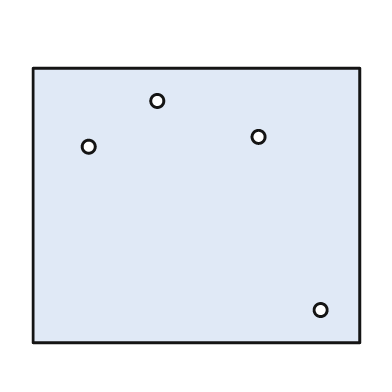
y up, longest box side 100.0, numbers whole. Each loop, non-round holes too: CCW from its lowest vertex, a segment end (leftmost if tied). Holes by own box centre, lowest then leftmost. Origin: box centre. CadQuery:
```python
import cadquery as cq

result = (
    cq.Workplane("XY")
    .moveTo(-50.0, -42.0)
    .lineTo(50.0, -42.0)
    .lineTo(50.0, 42.0)
    .lineTo(-50.0, 42.0)
    .close()
    .moveTo(38.0, -32.0)
    .circle(2.0)
    .moveTo(-33.0, 18.0)
    .circle(2.0)
    .moveTo(19.0, 21.0)
    .circle(2.0)
    .moveTo(-12.0, 32.0)
    .circle(2.0)
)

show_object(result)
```